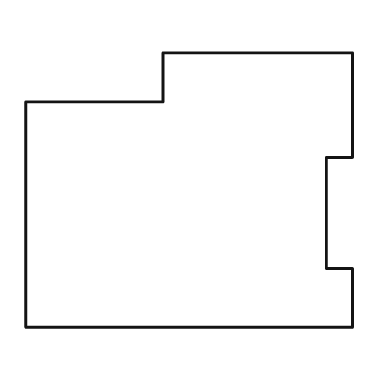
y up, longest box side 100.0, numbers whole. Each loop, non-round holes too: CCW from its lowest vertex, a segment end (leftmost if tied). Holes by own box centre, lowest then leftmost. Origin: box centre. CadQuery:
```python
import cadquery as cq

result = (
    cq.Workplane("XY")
    .moveTo(-50.0, -42.0)
    .lineTo(50.0, -42.0)
    .lineTo(50.0, -24.0)
    .lineTo(42.0, -24.0)
    .lineTo(42.0, 10.0)
    .lineTo(50.0, 10.0)
    .lineTo(50.0, 42.0)
    .lineTo(-8.0, 42.0)
    .lineTo(-8.0, 27.0)
    .lineTo(-50.0, 27.0)
    .close()
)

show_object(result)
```